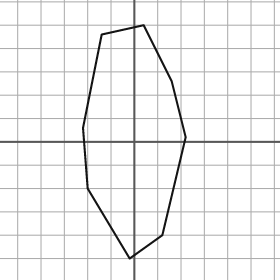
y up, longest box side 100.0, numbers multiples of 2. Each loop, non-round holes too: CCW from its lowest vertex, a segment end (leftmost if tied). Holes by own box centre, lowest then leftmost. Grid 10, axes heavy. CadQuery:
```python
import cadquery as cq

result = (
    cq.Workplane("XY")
    .moveTo(-2.0, -50.0)
    .lineTo(12.0, -40.0)
    .lineTo(22.0, 2.0)
    .lineTo(16.0, 26.0)
    .lineTo(4.0, 50.0)
    .lineTo(-14.0, 46.0)
    .lineTo(-22.0, 6.0)
    .lineTo(-20.0, -20.0)
    .close()
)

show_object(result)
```